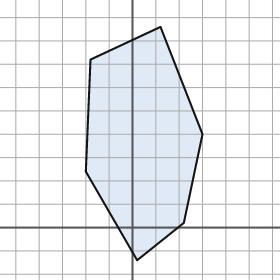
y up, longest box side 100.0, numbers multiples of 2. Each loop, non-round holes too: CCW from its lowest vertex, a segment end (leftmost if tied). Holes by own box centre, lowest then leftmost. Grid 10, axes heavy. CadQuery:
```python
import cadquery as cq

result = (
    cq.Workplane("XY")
    .moveTo(2.0, -14.0)
    .lineTo(22.0, 2.0)
    .lineTo(30.0, 40.0)
    .lineTo(12.0, 86.0)
    .lineTo(-18.0, 72.0)
    .lineTo(-20.0, 24.0)
    .close()
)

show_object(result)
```